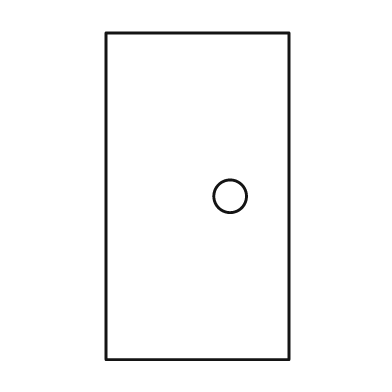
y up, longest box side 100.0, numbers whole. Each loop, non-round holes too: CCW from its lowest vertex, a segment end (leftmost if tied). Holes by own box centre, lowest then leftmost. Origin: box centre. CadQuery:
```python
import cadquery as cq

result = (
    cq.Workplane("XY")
    .moveTo(-28.0, -50.0)
    .lineTo(28.0, -50.0)
    .lineTo(28.0, 50.0)
    .lineTo(-28.0, 50.0)
    .close()
    .moveTo(10.0, 0.0)
    .circle(5.0)
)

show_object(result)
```